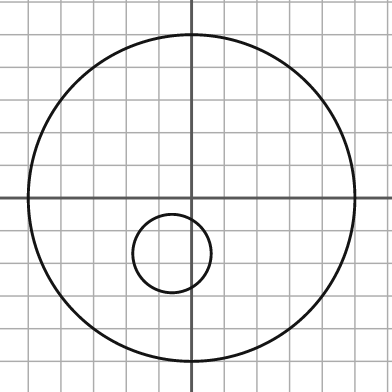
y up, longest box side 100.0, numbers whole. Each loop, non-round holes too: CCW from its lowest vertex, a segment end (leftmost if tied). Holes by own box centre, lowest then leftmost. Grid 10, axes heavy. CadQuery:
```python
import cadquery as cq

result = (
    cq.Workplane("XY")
    .moveTo(0.0, 0.0)
    .circle(50.0)
    .moveTo(-6.0, -17.0)
    .circle(12.0)
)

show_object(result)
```